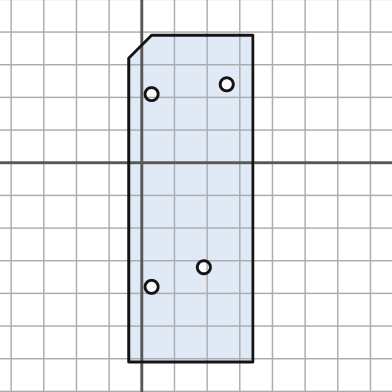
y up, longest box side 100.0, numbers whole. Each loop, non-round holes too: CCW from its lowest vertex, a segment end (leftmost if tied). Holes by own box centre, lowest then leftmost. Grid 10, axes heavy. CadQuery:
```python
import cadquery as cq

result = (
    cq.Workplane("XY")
    .moveTo(-4.0, -61.0)
    .lineTo(34.0, -61.0)
    .lineTo(34.0, 39.0)
    .lineTo(3.0, 39.0)
    .lineTo(-4.0, 32.0)
    .close()
    .moveTo(3.0, -38.0)
    .circle(2.0)
    .moveTo(19.0, -32.0)
    .circle(2.0)
    .moveTo(3.0, 21.0)
    .circle(2.0)
    .moveTo(26.0, 24.0)
    .circle(2.0)
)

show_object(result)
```